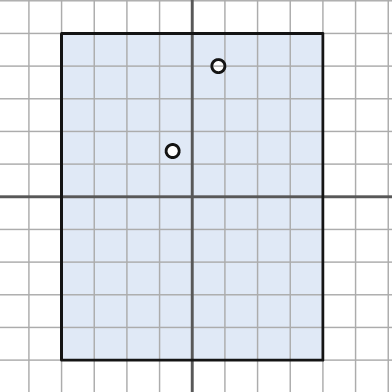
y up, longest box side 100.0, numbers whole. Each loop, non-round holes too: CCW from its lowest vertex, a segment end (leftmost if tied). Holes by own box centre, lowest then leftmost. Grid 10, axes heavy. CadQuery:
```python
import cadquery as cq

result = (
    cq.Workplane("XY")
    .moveTo(-40.0, -50.0)
    .lineTo(40.0, -50.0)
    .lineTo(40.0, 50.0)
    .lineTo(-40.0, 50.0)
    .close()
    .moveTo(-6.0, 14.0)
    .circle(2.0)
    .moveTo(8.0, 40.0)
    .circle(2.0)
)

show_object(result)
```